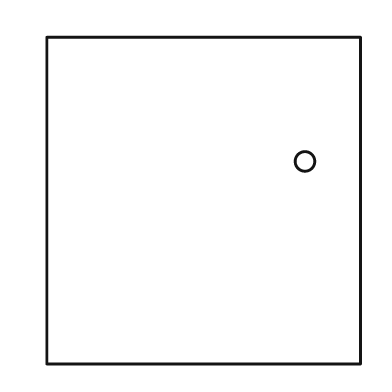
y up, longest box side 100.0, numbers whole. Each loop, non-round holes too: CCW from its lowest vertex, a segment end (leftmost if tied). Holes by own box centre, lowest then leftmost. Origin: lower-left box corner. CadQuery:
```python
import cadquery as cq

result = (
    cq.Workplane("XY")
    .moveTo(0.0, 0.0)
    .lineTo(96.0, 0.0)
    .lineTo(96.0, 100.0)
    .lineTo(0.0, 100.0)
    .close()
    .moveTo(79.0, 62.0)
    .circle(3.0)
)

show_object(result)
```